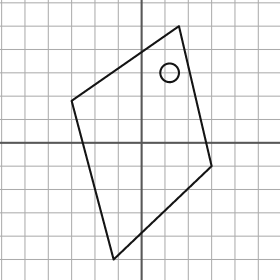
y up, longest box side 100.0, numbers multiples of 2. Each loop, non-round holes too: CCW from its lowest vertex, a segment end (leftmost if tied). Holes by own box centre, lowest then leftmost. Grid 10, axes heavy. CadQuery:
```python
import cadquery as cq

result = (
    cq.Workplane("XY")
    .moveTo(-12.0, -50.0)
    .lineTo(30.0, -10.0)
    .lineTo(16.0, 50.0)
    .lineTo(-30.0, 18.0)
    .close()
    .moveTo(12.0, 30.0)
    .circle(4.0)
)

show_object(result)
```